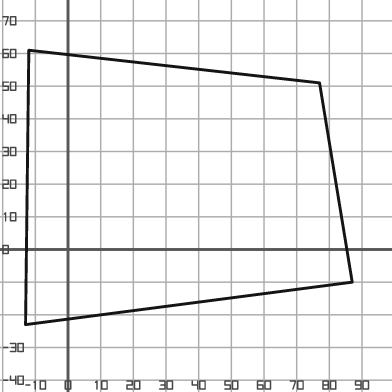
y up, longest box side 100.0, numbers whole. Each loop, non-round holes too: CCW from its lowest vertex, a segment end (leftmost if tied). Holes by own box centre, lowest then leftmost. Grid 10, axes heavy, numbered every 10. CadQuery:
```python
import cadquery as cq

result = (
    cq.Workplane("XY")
    .moveTo(-13.0, -23.0)
    .lineTo(87.0, -10.0)
    .lineTo(77.0, 51.0)
    .lineTo(-12.0, 61.0)
    .close()
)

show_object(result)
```